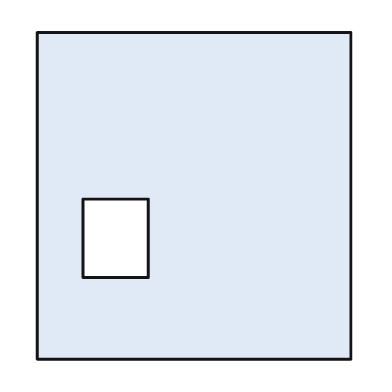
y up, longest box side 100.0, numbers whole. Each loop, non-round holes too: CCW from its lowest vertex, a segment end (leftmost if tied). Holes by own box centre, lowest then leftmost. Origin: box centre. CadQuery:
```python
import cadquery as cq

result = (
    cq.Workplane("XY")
    .moveTo(-48.0, -50.0)
    .lineTo(48.0, -50.0)
    .lineTo(48.0, 50.0)
    .lineTo(-48.0, 50.0)
    .close()
    .moveTo(-34.0, -25.0)
    .lineTo(-14.0, -25.0)
    .lineTo(-14.0, -1.0)
    .lineTo(-34.0, -1.0)
    .close()
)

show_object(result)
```